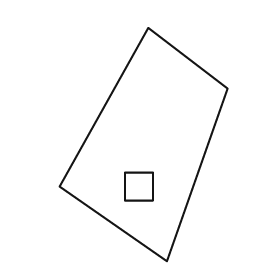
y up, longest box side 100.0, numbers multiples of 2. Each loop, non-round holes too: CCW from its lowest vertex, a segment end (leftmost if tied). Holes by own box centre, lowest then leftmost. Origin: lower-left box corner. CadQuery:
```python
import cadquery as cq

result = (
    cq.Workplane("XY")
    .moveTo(46.0, 0.0)
    .lineTo(72.0, 74.0)
    .lineTo(38.0, 100.0)
    .lineTo(0.0, 32.0)
    .close()
    .moveTo(28.0, 26.0)
    .lineTo(40.0, 26.0)
    .lineTo(40.0, 38.0)
    .lineTo(28.0, 38.0)
    .close()
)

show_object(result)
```